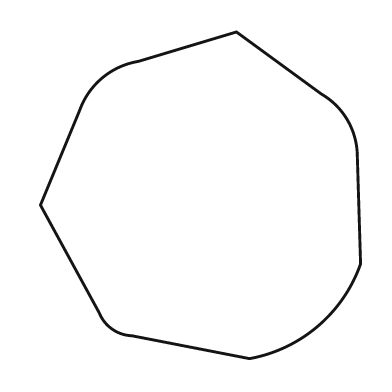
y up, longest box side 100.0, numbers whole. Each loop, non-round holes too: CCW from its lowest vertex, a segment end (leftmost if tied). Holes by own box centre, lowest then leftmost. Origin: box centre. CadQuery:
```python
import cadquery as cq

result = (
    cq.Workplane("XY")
    .moveTo(15.0, -50.0)
    .threePointArc((36.0, -40.0), (49.0, -21.0))
    .lineTo(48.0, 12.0)
    .threePointArc((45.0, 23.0), (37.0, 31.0))
    .lineTo(11.0, 50.0)
    .lineTo(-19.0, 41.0)
    .threePointArc((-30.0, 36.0), (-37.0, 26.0))
    .lineTo(-49.0, -3.0)
    .lineTo(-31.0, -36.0)
    .threePointArc((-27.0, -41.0), (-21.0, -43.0))
    .close()
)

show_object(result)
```